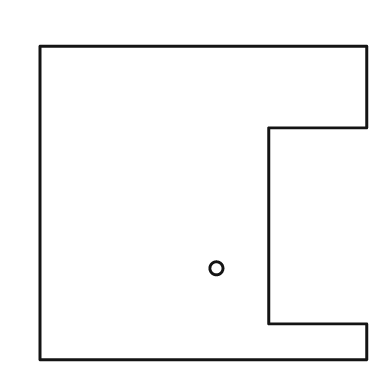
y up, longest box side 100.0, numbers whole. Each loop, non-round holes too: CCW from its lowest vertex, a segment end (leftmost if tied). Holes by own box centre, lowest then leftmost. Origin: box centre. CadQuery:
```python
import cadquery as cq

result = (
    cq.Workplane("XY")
    .moveTo(-50.0, -48.0)
    .lineTo(50.0, -48.0)
    .lineTo(50.0, -37.0)
    .lineTo(20.0, -37.0)
    .lineTo(20.0, 23.0)
    .lineTo(50.0, 23.0)
    .lineTo(50.0, 48.0)
    .lineTo(-50.0, 48.0)
    .close()
    .moveTo(4.0, -20.0)
    .circle(2.0)
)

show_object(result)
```